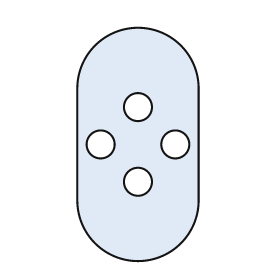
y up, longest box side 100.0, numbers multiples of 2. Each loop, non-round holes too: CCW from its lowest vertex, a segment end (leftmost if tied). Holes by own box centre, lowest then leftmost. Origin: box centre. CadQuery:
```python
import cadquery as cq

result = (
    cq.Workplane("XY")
    .moveTo(-26.0, -24.0)
    .threePointArc((0.0, -50.0), (26.0, -24.0))
    .lineTo(26.0, 24.0)
    .threePointArc((0.0, 50.0), (-26.0, 24.0))
    .close()
    .moveTo(0.0, -16.0)
    .circle(6.0)
    .moveTo(-16.0, 0.0)
    .circle(6.0)
    .moveTo(16.0, 0.0)
    .circle(6.0)
    .moveTo(0.0, 16.0)
    .circle(6.0)
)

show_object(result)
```